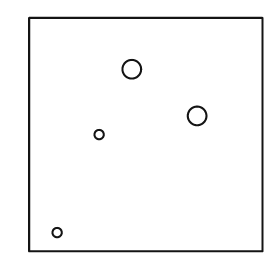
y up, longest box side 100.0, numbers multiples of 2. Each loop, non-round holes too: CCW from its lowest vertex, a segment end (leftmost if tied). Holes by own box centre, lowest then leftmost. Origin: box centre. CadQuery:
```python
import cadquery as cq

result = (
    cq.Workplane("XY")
    .moveTo(-50.0, -50.0)
    .lineTo(50.0, -50.0)
    .lineTo(50.0, 50.0)
    .lineTo(-50.0, 50.0)
    .close()
    .moveTo(-38.0, -42.0)
    .circle(2.0)
    .moveTo(-20.0, 0.0)
    .circle(2.0)
    .moveTo(22.0, 8.0)
    .circle(4.0)
    .moveTo(-6.0, 28.0)
    .circle(4.0)
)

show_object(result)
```